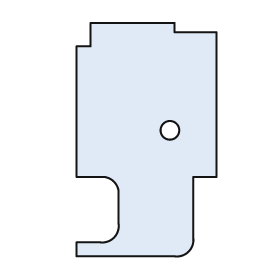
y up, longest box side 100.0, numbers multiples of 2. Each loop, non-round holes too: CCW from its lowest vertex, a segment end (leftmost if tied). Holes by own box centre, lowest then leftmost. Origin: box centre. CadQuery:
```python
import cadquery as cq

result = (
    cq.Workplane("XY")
    .moveTo(-30.0, -50.0)
    .lineTo(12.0, -50.0)
    .threePointArc((18.0, -48.0), (20.0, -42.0))
    .lineTo(20.0, -16.0)
    .lineTo(30.0, -16.0)
    .lineTo(30.0, 46.0)
    .lineTo(12.0, 46.0)
    .lineTo(12.0, 50.0)
    .lineTo(-24.0, 50.0)
    .lineTo(-24.0, 40.0)
    .lineTo(-30.0, 40.0)
    .lineTo(-30.0, -16.0)
    .lineTo(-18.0, -16.0)
    .threePointArc((-14.0, -18.0), (-12.0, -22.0))
    .lineTo(-12.0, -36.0)
    .threePointArc((-14.0, -42.0), (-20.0, -44.0))
    .lineTo(-30.0, -44.0)
    .close()
    .moveTo(10.0, 4.0)
    .circle(4.0)
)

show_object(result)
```